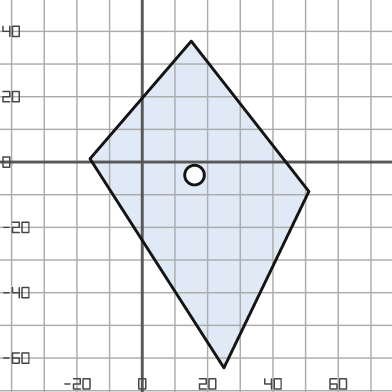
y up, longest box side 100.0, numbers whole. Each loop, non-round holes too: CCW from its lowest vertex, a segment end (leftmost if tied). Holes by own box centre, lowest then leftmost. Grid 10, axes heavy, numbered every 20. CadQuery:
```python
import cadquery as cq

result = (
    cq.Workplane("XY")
    .moveTo(25.0, -63.0)
    .lineTo(51.0, -9.0)
    .lineTo(15.0, 37.0)
    .lineTo(-16.0, 1.0)
    .close()
    .moveTo(16.0, -4.0)
    .circle(3.0)
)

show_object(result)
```